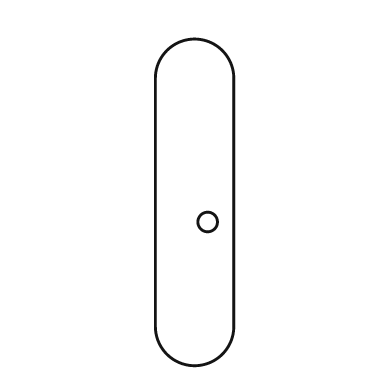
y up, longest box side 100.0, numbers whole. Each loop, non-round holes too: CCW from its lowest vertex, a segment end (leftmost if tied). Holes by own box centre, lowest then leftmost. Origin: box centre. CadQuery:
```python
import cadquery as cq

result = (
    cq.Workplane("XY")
    .moveTo(-12.0, -38.0)
    .threePointArc((0.0, -50.0), (12.0, -38.0))
    .lineTo(12.0, 38.0)
    .threePointArc((0.0, 50.0), (-12.0, 38.0))
    .close()
    .moveTo(4.0, -6.0)
    .circle(3.0)
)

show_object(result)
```